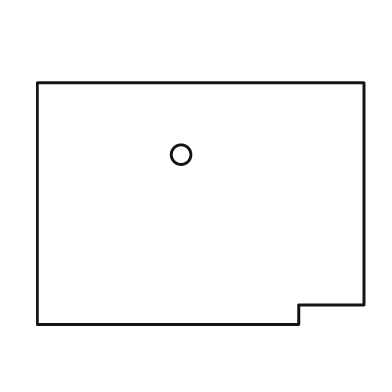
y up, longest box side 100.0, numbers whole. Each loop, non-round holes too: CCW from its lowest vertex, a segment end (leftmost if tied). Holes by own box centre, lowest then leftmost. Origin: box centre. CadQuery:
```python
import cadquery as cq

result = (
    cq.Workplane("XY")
    .moveTo(-50.0, -37.0)
    .lineTo(30.0, -37.0)
    .lineTo(30.0, -31.0)
    .lineTo(50.0, -31.0)
    .lineTo(50.0, 37.0)
    .lineTo(-50.0, 37.0)
    .close()
    .moveTo(-6.0, 15.0)
    .circle(3.0)
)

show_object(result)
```